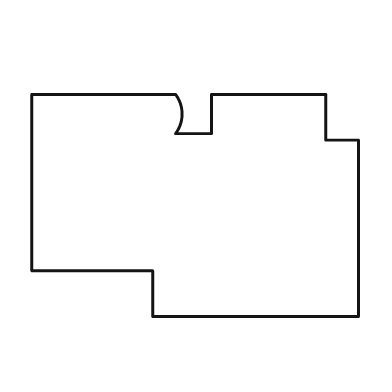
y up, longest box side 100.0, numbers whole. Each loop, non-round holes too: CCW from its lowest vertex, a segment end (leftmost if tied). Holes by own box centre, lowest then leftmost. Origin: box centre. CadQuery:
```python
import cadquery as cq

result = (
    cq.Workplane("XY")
    .moveTo(-13.0, -34.0)
    .lineTo(50.0, -34.0)
    .lineTo(50.0, 20.0)
    .lineTo(40.0, 20.0)
    .lineTo(40.0, 34.0)
    .lineTo(5.0, 34.0)
    .lineTo(5.0, 22.0)
    .lineTo(-6.0, 22.0)
    .threePointArc((-4.0, 28.0), (-6.0, 34.0))
    .lineTo(-50.0, 34.0)
    .lineTo(-50.0, -20.0)
    .lineTo(-13.0, -20.0)
    .close()
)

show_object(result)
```